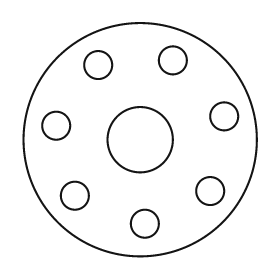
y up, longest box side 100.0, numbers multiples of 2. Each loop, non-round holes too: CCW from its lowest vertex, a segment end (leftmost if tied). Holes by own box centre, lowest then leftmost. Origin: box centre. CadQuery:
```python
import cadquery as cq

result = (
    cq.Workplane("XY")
    .moveTo(0.0, 0.0)
    .circle(50.0)
    .moveTo(2.0, -36.0)
    .circle(6.0)
    .moveTo(-28.0, -24.0)
    .circle(6.0)
    .moveTo(30.0, -22.0)
    .circle(6.0)
    .moveTo(0.0, 0.0)
    .circle(14.0)
    .moveTo(-36.0, 6.0)
    .circle(6.0)
    .moveTo(36.0, 10.0)
    .circle(6.0)
    .moveTo(-18.0, 32.0)
    .circle(6.0)
    .moveTo(14.0, 34.0)
    .circle(6.0)
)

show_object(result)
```